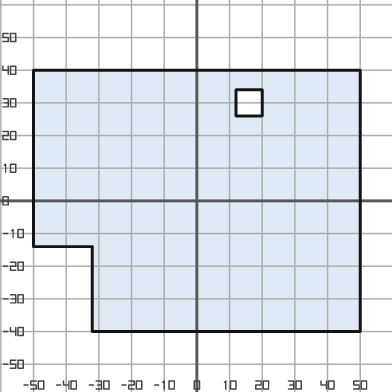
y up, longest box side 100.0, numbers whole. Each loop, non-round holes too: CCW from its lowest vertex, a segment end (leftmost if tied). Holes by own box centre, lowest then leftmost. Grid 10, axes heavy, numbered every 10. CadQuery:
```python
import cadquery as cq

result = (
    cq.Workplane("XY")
    .moveTo(-32.0, -40.0)
    .lineTo(50.0, -40.0)
    .lineTo(50.0, 40.0)
    .lineTo(-50.0, 40.0)
    .lineTo(-50.0, -14.0)
    .lineTo(-32.0, -14.0)
    .close()
    .moveTo(12.0, 26.0)
    .lineTo(20.0, 26.0)
    .lineTo(20.0, 34.0)
    .lineTo(12.0, 34.0)
    .close()
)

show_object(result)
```